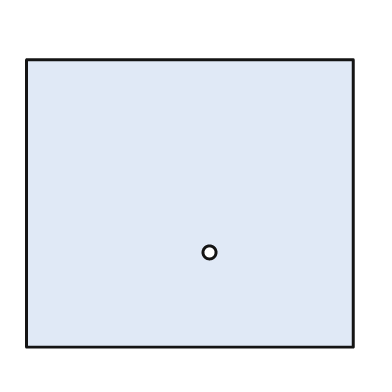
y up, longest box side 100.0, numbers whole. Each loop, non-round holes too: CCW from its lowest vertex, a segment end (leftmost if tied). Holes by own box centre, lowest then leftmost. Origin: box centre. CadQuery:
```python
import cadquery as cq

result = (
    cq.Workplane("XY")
    .moveTo(-50.0, -44.0)
    .lineTo(50.0, -44.0)
    .lineTo(50.0, 44.0)
    .lineTo(-50.0, 44.0)
    .close()
    .moveTo(6.0, -15.0)
    .circle(2.0)
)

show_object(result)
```